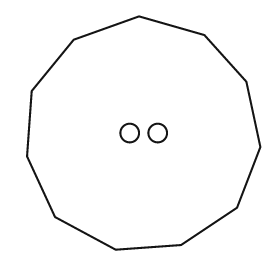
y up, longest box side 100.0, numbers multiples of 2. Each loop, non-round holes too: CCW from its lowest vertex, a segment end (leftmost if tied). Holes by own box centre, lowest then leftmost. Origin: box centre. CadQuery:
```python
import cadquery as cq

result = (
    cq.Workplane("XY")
    .moveTo(-12.0, -50.0)
    .lineTo(16.0, -48.0)
    .lineTo(40.0, -32.0)
    .lineTo(50.0, -6.0)
    .lineTo(44.0, 22.0)
    .lineTo(26.0, 42.0)
    .lineTo(-2.0, 50.0)
    .lineTo(-30.0, 40.0)
    .lineTo(-48.0, 18.0)
    .lineTo(-50.0, -10.0)
    .lineTo(-38.0, -36.0)
    .close()
    .moveTo(-6.0, 0.0)
    .circle(4.0)
    .moveTo(6.0, 0.0)
    .circle(4.0)
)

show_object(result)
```